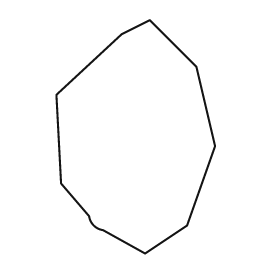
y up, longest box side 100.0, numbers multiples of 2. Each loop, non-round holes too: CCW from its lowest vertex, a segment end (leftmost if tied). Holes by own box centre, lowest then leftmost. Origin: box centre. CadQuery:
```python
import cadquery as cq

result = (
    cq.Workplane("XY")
    .moveTo(4.0, -50.0)
    .lineTo(22.0, -38.0)
    .lineTo(34.0, -4.0)
    .lineTo(26.0, 30.0)
    .lineTo(6.0, 50.0)
    .lineTo(-6.0, 44.0)
    .lineTo(-34.0, 18.0)
    .lineTo(-32.0, -20.0)
    .lineTo(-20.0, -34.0)
    .threePointArc((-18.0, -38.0), (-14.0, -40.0))
    .close()
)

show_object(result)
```